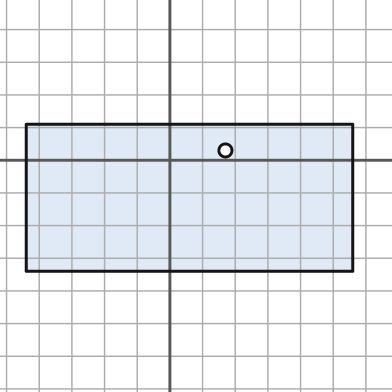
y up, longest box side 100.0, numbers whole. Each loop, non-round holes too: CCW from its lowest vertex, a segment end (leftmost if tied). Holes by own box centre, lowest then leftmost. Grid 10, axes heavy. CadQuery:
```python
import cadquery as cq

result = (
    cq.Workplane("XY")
    .moveTo(-44.0, -34.0)
    .lineTo(56.0, -34.0)
    .lineTo(56.0, 11.0)
    .lineTo(-44.0, 11.0)
    .close()
    .moveTo(17.0, 3.0)
    .circle(2.0)
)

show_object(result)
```